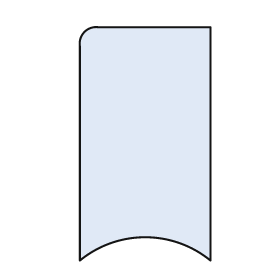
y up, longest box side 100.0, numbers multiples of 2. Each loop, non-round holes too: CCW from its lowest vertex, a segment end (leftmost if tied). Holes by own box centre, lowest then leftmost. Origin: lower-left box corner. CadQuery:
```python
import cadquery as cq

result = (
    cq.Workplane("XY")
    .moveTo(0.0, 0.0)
    .threePointArc((28.0, 10.0), (56.0, 0.0))
    .lineTo(56.0, 100.0)
    .lineTo(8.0, 100.0)
    .threePointArc((2.0, 98.0), (0.0, 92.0))
    .close()
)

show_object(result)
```